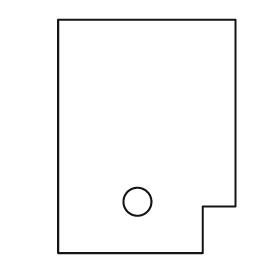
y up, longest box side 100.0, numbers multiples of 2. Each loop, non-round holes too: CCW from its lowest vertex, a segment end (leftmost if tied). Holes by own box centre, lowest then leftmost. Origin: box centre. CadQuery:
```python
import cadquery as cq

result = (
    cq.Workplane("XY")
    .moveTo(-38.0, -50.0)
    .lineTo(24.0, -50.0)
    .lineTo(24.0, -30.0)
    .lineTo(38.0, -30.0)
    .lineTo(38.0, 50.0)
    .lineTo(-38.0, 50.0)
    .close()
    .moveTo(-4.0, -28.0)
    .circle(6.0)
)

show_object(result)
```